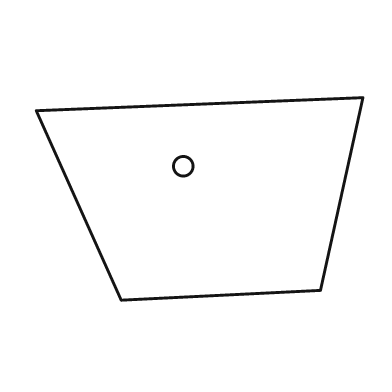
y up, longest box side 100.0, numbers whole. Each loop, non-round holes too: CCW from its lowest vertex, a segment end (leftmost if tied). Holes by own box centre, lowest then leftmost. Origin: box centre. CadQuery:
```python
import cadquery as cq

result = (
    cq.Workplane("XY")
    .moveTo(-24.0, -31.0)
    .lineTo(37.0, -28.0)
    .lineTo(50.0, 31.0)
    .lineTo(-50.0, 27.0)
    .close()
    .moveTo(-5.0, 10.0)
    .circle(3.0)
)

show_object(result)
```